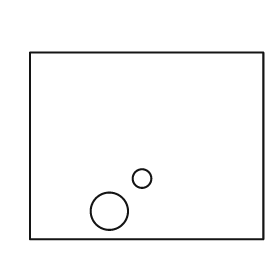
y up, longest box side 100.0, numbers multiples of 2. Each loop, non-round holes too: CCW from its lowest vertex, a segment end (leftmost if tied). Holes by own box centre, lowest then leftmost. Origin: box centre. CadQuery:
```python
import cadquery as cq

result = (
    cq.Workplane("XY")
    .moveTo(-50.0, -40.0)
    .lineTo(50.0, -40.0)
    .lineTo(50.0, 40.0)
    .lineTo(-50.0, 40.0)
    .close()
    .moveTo(-16.0, -28.0)
    .circle(8.0)
    .moveTo(-2.0, -14.0)
    .circle(4.0)
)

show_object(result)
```